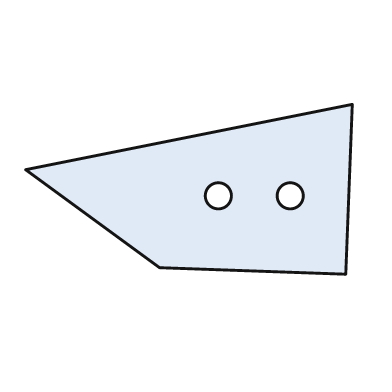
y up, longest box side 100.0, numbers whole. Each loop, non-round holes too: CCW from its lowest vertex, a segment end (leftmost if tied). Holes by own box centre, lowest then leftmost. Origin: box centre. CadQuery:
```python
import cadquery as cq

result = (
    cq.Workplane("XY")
    .moveTo(48.0, -26.0)
    .lineTo(50.0, 26.0)
    .lineTo(-50.0, 6.0)
    .lineTo(-9.0, -24.0)
    .close()
    .moveTo(9.0, -2.0)
    .circle(4.0)
    .moveTo(31.0, -2.0)
    .circle(4.0)
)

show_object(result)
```